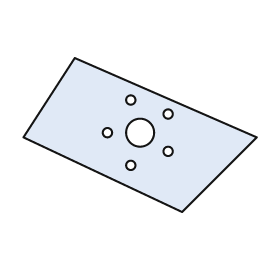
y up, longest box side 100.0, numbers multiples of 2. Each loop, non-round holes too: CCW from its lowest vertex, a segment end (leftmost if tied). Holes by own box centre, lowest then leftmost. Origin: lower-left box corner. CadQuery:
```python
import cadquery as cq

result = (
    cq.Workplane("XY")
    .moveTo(68.0, 0.0)
    .lineTo(100.0, 32.0)
    .lineTo(22.0, 66.0)
    .lineTo(0.0, 32.0)
    .close()
    .moveTo(46.0, 20.0)
    .circle(2.0)
    .moveTo(62.0, 26.0)
    .circle(2.0)
    .moveTo(36.0, 34.0)
    .circle(2.0)
    .moveTo(50.0, 34.0)
    .circle(6.0)
    .moveTo(62.0, 42.0)
    .circle(2.0)
    .moveTo(46.0, 48.0)
    .circle(2.0)
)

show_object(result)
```